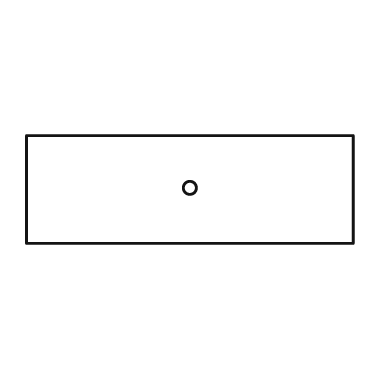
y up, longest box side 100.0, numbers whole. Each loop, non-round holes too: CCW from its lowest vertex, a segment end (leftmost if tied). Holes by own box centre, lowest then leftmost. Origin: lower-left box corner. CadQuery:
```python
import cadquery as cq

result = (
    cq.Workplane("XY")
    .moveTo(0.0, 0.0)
    .lineTo(100.0, 0.0)
    .lineTo(100.0, 33.0)
    .lineTo(0.0, 33.0)
    .close()
    .moveTo(50.0, 17.0)
    .circle(2.0)
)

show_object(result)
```